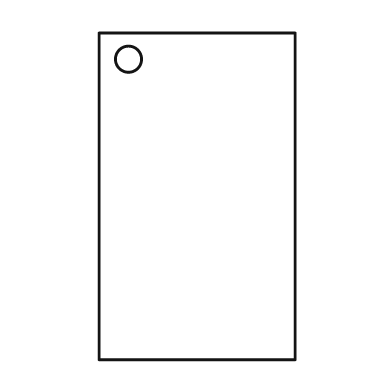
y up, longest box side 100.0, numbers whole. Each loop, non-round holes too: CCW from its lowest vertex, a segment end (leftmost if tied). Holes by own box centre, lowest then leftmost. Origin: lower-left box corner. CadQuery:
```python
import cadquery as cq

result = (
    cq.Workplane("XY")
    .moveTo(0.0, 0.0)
    .lineTo(60.0, 0.0)
    .lineTo(60.0, 100.0)
    .lineTo(0.0, 100.0)
    .close()
    .moveTo(9.0, 92.0)
    .circle(4.0)
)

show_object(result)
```